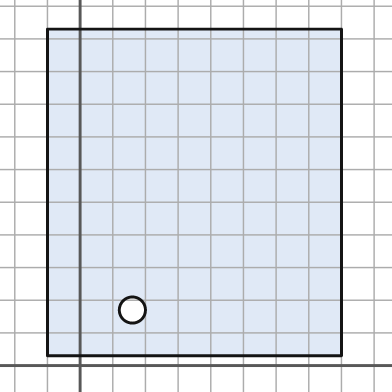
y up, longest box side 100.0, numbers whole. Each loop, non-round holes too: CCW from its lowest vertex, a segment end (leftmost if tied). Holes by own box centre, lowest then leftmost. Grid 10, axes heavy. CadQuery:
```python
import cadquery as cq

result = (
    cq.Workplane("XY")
    .moveTo(-10.0, 3.0)
    .lineTo(80.0, 3.0)
    .lineTo(80.0, 103.0)
    .lineTo(-10.0, 103.0)
    .close()
    .moveTo(16.0, 17.0)
    .circle(4.0)
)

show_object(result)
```